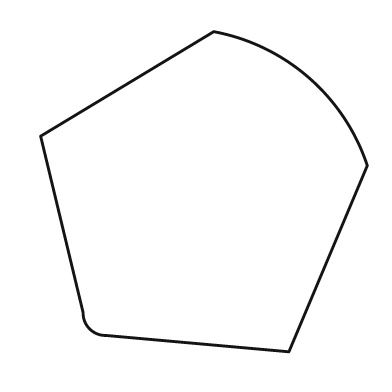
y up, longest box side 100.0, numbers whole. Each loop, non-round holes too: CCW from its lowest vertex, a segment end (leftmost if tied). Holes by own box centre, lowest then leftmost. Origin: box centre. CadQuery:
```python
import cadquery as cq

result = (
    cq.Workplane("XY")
    .moveTo(26.0, -49.0)
    .lineTo(50.0, 8.0)
    .threePointArc((32.0, 35.0), (3.0, 49.0))
    .lineTo(-50.0, 17.0)
    .lineTo(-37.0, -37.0)
    .threePointArc((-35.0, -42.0), (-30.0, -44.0))
    .close()
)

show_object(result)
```